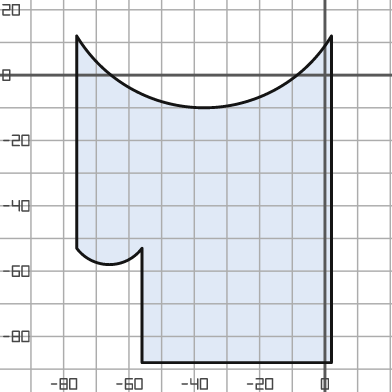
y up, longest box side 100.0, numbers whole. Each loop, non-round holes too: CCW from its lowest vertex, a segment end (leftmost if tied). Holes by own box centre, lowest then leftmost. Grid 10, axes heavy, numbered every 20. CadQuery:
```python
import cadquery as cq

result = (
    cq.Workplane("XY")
    .moveTo(-56.0, -88.0)
    .lineTo(2.0, -88.0)
    .lineTo(2.0, 12.0)
    .threePointArc((-37.0, -10.0), (-76.0, 12.0))
    .lineTo(-76.0, -53.0)
    .threePointArc((-66.0, -58.0), (-56.0, -53.0))
    .close()
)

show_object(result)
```